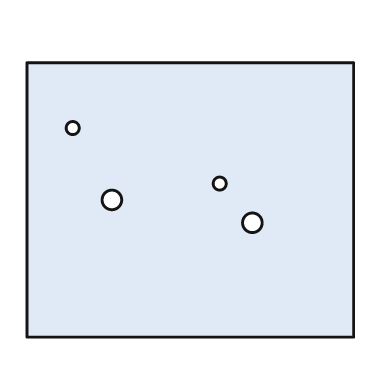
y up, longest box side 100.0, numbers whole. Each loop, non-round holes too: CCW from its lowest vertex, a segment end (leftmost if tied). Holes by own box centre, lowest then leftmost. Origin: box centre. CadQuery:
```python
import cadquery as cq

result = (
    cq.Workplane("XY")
    .moveTo(-50.0, -42.0)
    .lineTo(50.0, -42.0)
    .lineTo(50.0, 42.0)
    .lineTo(-50.0, 42.0)
    .close()
    .moveTo(19.0, -7.0)
    .circle(3.0)
    .moveTo(-24.0, 0.0)
    .circle(3.0)
    .moveTo(9.0, 5.0)
    .circle(2.0)
    .moveTo(-36.0, 22.0)
    .circle(2.0)
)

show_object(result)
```